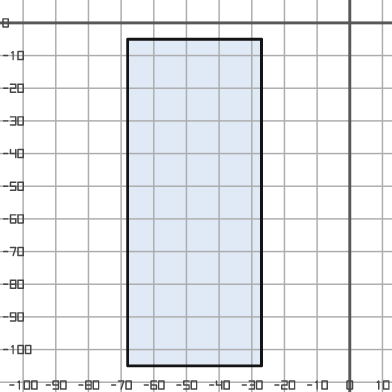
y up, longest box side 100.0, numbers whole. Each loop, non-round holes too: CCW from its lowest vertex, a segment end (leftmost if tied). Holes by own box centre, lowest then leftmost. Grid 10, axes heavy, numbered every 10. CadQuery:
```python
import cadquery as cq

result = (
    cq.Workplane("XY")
    .moveTo(-68.0, -105.0)
    .lineTo(-27.0, -105.0)
    .lineTo(-27.0, -5.0)
    .lineTo(-68.0, -5.0)
    .close()
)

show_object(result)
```